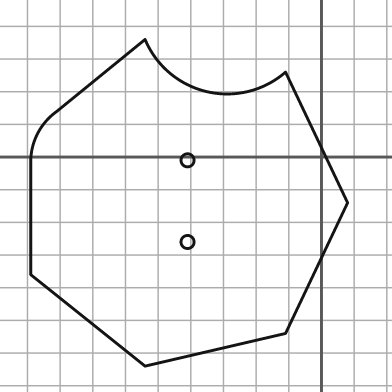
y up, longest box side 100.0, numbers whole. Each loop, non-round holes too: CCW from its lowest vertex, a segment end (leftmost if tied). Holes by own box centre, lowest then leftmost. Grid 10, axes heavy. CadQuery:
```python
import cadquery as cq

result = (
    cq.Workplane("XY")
    .moveTo(-54.0, -64.0)
    .lineTo(-11.0, -54.0)
    .lineTo(8.0, -14.0)
    .lineTo(-11.0, 26.0)
    .threePointArc((-35.0, 20.0), (-54.0, 36.0))
    .lineTo(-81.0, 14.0)
    .threePointArc((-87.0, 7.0), (-89.0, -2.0))
    .lineTo(-89.0, -36.0)
    .close()
    .moveTo(-41.0, -26.0)
    .circle(2.0)
    .moveTo(-41.0, -1.0)
    .circle(2.0)
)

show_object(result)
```